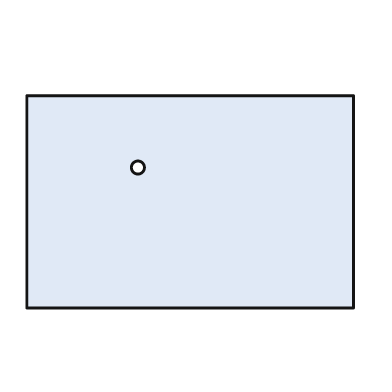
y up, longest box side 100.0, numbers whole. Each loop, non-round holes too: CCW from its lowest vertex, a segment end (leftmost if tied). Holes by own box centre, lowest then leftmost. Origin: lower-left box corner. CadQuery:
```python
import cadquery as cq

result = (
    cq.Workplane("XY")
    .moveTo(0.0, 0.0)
    .lineTo(100.0, 0.0)
    .lineTo(100.0, 65.0)
    .lineTo(0.0, 65.0)
    .close()
    .moveTo(34.0, 43.0)
    .circle(2.0)
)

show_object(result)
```